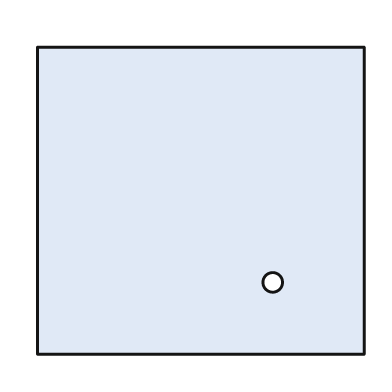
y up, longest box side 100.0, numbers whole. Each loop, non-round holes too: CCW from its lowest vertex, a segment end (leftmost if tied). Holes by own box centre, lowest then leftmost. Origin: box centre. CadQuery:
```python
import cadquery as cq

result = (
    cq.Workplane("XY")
    .moveTo(-50.0, -47.0)
    .lineTo(50.0, -47.0)
    .lineTo(50.0, 47.0)
    .lineTo(-50.0, 47.0)
    .close()
    .moveTo(22.0, -25.0)
    .circle(3.0)
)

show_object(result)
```